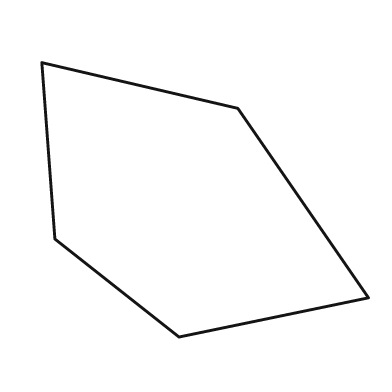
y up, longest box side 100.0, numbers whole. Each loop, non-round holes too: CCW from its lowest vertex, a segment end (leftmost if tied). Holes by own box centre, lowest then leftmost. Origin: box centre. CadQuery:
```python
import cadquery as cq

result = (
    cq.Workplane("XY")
    .moveTo(-8.0, -42.0)
    .lineTo(50.0, -30.0)
    .lineTo(10.0, 28.0)
    .lineTo(-50.0, 42.0)
    .lineTo(-46.0, -12.0)
    .close()
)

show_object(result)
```